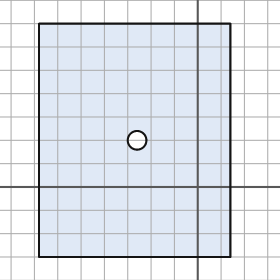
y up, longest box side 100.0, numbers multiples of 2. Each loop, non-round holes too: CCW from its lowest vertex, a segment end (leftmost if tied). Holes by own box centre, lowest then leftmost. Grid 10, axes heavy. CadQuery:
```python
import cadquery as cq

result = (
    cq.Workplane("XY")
    .moveTo(-68.0, -30.0)
    .lineTo(14.0, -30.0)
    .lineTo(14.0, 70.0)
    .lineTo(-68.0, 70.0)
    .close()
    .moveTo(-26.0, 20.0)
    .circle(4.0)
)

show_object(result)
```